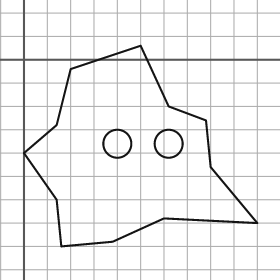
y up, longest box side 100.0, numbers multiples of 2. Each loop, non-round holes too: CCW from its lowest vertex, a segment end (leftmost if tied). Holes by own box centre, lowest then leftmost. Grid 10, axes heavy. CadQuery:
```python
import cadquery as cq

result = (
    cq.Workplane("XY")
    .moveTo(16.0, -80.0)
    .lineTo(38.0, -78.0)
    .lineTo(60.0, -68.0)
    .lineTo(100.0, -70.0)
    .lineTo(80.0, -46.0)
    .lineTo(78.0, -26.0)
    .lineTo(62.0, -20.0)
    .lineTo(50.0, 6.0)
    .lineTo(20.0, -4.0)
    .lineTo(14.0, -28.0)
    .lineTo(0.0, -40.0)
    .lineTo(14.0, -60.0)
    .close()
    .moveTo(40.0, -36.0)
    .circle(6.0)
    .moveTo(62.0, -36.0)
    .circle(6.0)
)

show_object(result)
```